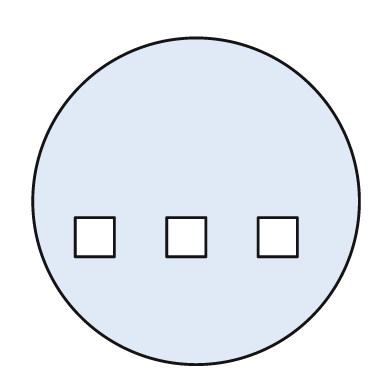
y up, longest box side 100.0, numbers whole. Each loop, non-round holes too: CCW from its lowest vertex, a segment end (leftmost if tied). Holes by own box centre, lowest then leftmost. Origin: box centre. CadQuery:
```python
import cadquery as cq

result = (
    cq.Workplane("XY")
    .moveTo(0.0, 0.0)
    .circle(50.0)
    .moveTo(-37.0, -17.0)
    .lineTo(-25.0, -17.0)
    .lineTo(-25.0, -5.0)
    .lineTo(-37.0, -5.0)
    .close()
    .moveTo(-9.0, -17.0)
    .lineTo(3.0, -17.0)
    .lineTo(3.0, -5.0)
    .lineTo(-9.0, -5.0)
    .close()
    .moveTo(19.0, -17.0)
    .lineTo(31.0, -17.0)
    .lineTo(31.0, -5.0)
    .lineTo(19.0, -5.0)
    .close()
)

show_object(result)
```